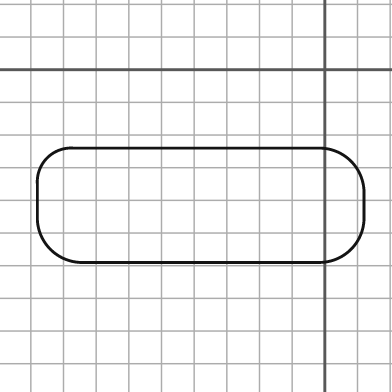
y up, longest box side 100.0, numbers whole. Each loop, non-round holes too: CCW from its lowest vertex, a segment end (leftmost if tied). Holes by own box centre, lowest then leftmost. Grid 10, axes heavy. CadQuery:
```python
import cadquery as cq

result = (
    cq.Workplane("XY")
    .moveTo(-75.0, -59.0)
    .lineTo(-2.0, -59.0)
    .threePointArc((8.0, -55.0), (12.0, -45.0))
    .lineTo(12.0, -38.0)
    .threePointArc((8.0, -28.0), (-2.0, -24.0))
    .lineTo(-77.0, -24.0)
    .threePointArc((-85.0, -27.0), (-88.0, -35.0))
    .lineTo(-88.0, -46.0)
    .threePointArc((-84.0, -55.0), (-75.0, -59.0))
    .close()
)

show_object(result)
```